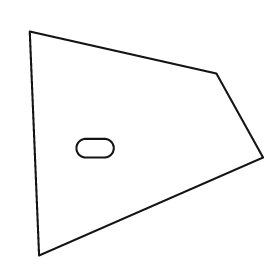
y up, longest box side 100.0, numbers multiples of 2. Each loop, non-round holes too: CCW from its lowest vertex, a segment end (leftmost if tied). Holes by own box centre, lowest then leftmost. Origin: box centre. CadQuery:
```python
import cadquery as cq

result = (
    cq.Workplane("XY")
    .moveTo(-46.0, -48.0)
    .lineTo(50.0, -6.0)
    .lineTo(30.0, 30.0)
    .lineTo(-50.0, 48.0)
    .close()
    .moveTo(-26.0, -6.0)
    .lineTo(-18.0, -6.0)
    .threePointArc((-14.0, -2.0), (-18.0, 2.0))
    .lineTo(-26.0, 2.0)
    .threePointArc((-30.0, -2.0), (-26.0, -6.0))
    .close()
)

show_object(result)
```